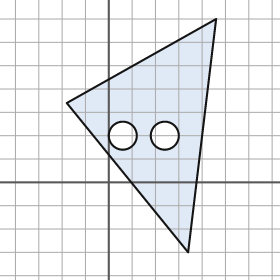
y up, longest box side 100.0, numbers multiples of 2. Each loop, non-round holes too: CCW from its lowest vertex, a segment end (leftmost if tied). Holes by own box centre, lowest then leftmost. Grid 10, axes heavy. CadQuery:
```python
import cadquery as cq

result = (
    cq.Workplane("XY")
    .moveTo(34.0, -30.0)
    .lineTo(46.0, 70.0)
    .lineTo(-18.0, 34.0)
    .close()
    .moveTo(6.0, 20.0)
    .circle(6.0)
    .moveTo(24.0, 20.0)
    .circle(6.0)
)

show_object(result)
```